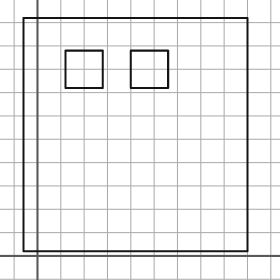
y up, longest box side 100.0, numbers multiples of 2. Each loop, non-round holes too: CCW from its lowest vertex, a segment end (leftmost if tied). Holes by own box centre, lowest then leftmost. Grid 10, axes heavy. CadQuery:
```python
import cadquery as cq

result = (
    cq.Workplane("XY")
    .moveTo(-6.0, 2.0)
    .lineTo(90.0, 2.0)
    .lineTo(90.0, 102.0)
    .lineTo(-6.0, 102.0)
    .close()
    .moveTo(12.0, 72.0)
    .lineTo(28.0, 72.0)
    .lineTo(28.0, 88.0)
    .lineTo(12.0, 88.0)
    .close()
    .moveTo(40.0, 72.0)
    .lineTo(56.0, 72.0)
    .lineTo(56.0, 88.0)
    .lineTo(40.0, 88.0)
    .close()
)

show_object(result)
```